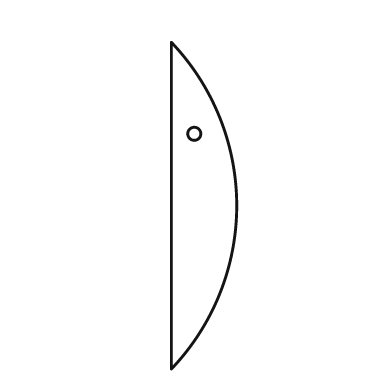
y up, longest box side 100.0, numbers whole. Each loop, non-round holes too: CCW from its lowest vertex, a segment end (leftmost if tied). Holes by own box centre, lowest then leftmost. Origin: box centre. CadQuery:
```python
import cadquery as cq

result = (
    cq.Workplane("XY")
    .moveTo(-10.0, -50.0)
    .threePointArc((10.0, 0.0), (-10.0, 50.0))
    .close()
    .moveTo(-3.0, 22.0)
    .circle(2.0)
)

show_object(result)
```